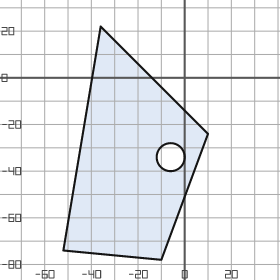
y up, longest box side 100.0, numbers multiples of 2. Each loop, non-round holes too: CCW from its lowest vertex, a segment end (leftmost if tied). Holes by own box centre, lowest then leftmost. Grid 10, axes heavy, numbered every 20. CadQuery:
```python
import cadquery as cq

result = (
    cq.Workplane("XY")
    .moveTo(-10.0, -78.0)
    .lineTo(10.0, -24.0)
    .lineTo(-36.0, 22.0)
    .lineTo(-52.0, -74.0)
    .close()
    .moveTo(-6.0, -34.0)
    .circle(6.0)
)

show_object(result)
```